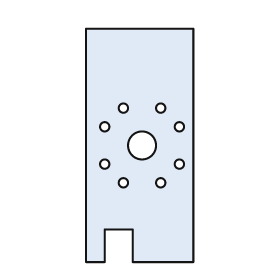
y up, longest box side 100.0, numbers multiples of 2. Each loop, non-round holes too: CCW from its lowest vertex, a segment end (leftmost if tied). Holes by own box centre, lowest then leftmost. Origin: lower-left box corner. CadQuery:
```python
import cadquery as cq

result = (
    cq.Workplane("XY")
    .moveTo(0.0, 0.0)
    .lineTo(8.0, 0.0)
    .lineTo(8.0, 14.0)
    .lineTo(20.0, 14.0)
    .lineTo(20.0, 0.0)
    .lineTo(46.0, 0.0)
    .lineTo(46.0, 100.0)
    .lineTo(0.0, 100.0)
    .close()
    .moveTo(16.0, 34.0)
    .circle(2.0)
    .moveTo(32.0, 34.0)
    .circle(2.0)
    .moveTo(8.0, 42.0)
    .circle(2.0)
    .moveTo(40.0, 42.0)
    .circle(2.0)
    .moveTo(24.0, 50.0)
    .circle(6.0)
    .moveTo(8.0, 58.0)
    .circle(2.0)
    .moveTo(40.0, 58.0)
    .circle(2.0)
    .moveTo(16.0, 66.0)
    .circle(2.0)
    .moveTo(32.0, 66.0)
    .circle(2.0)
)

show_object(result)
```